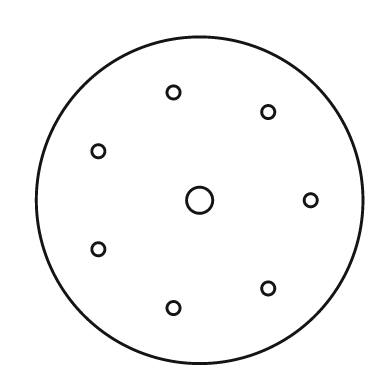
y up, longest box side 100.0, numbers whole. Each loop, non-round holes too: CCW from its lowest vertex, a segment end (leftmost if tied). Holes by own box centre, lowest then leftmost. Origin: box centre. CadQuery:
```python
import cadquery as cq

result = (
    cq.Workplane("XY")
    .moveTo(0.0, 0.0)
    .circle(50.0)
    .moveTo(-8.0, -33.0)
    .circle(2.0)
    .moveTo(21.0, -27.0)
    .circle(2.0)
    .moveTo(-31.0, -15.0)
    .circle(2.0)
    .moveTo(0.0, 0.0)
    .circle(4.0)
    .moveTo(34.0, 0.0)
    .circle(2.0)
    .moveTo(-31.0, 15.0)
    .circle(2.0)
    .moveTo(21.0, 27.0)
    .circle(2.0)
    .moveTo(-8.0, 33.0)
    .circle(2.0)
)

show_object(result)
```